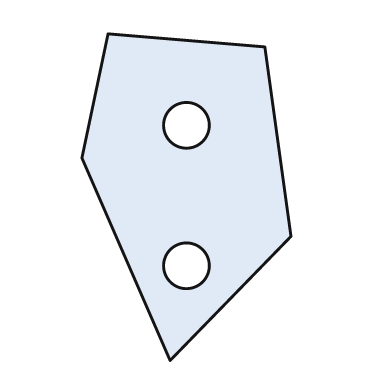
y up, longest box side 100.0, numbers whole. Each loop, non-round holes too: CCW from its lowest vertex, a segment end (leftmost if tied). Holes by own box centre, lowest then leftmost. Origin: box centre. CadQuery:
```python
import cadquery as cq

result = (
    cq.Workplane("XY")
    .moveTo(-5.0, -50.0)
    .lineTo(32.0, -12.0)
    .lineTo(24.0, 46.0)
    .lineTo(-24.0, 50.0)
    .lineTo(-32.0, 12.0)
    .close()
    .moveTo(0.0, -21.0)
    .circle(7.0)
    .moveTo(0.0, 22.0)
    .circle(7.0)
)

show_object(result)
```